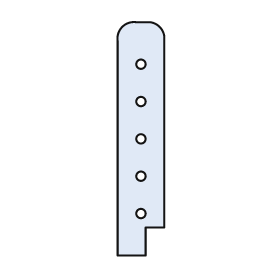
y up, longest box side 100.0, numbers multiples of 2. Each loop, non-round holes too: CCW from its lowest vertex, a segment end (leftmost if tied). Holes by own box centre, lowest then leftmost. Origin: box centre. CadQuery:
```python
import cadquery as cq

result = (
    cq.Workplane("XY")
    .moveTo(-10.0, -50.0)
    .lineTo(2.0, -50.0)
    .lineTo(2.0, -38.0)
    .lineTo(10.0, -38.0)
    .lineTo(10.0, 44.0)
    .threePointArc((8.0, 48.0), (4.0, 50.0))
    .lineTo(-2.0, 50.0)
    .threePointArc((-8.0, 48.0), (-10.0, 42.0))
    .close()
    .moveTo(0.0, -32.0)
    .circle(2.0)
    .moveTo(0.0, -16.0)
    .circle(2.0)
    .moveTo(0.0, 0.0)
    .circle(2.0)
    .moveTo(0.0, 16.0)
    .circle(2.0)
    .moveTo(0.0, 32.0)
    .circle(2.0)
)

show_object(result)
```